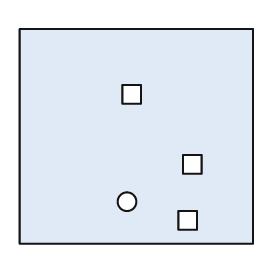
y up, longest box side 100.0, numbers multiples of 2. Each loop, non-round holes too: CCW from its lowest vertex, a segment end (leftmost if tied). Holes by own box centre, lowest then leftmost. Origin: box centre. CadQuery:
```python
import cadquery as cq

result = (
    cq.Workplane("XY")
    .moveTo(-50.0, -46.0)
    .lineTo(50.0, -46.0)
    .lineTo(50.0, 46.0)
    .lineTo(-50.0, 46.0)
    .close()
    .moveTo(18.0, -40.0)
    .lineTo(26.0, -40.0)
    .lineTo(26.0, -32.0)
    .lineTo(18.0, -32.0)
    .close()
    .moveTo(-4.0, -28.0)
    .circle(4.0)
    .moveTo(20.0, -16.0)
    .lineTo(28.0, -16.0)
    .lineTo(28.0, -8.0)
    .lineTo(20.0, -8.0)
    .close()
    .moveTo(-6.0, 14.0)
    .lineTo(2.0, 14.0)
    .lineTo(2.0, 22.0)
    .lineTo(-6.0, 22.0)
    .close()
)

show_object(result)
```